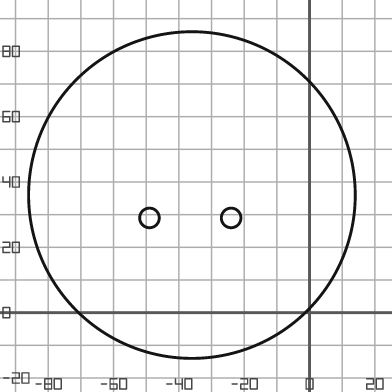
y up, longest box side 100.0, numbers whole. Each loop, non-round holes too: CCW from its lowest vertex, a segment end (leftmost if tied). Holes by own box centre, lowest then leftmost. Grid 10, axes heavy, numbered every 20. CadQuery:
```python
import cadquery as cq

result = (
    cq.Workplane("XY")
    .moveTo(-36.0, 36.0)
    .circle(50.0)
    .moveTo(-49.0, 29.0)
    .circle(3.0)
    .moveTo(-24.0, 29.0)
    .circle(3.0)
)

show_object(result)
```